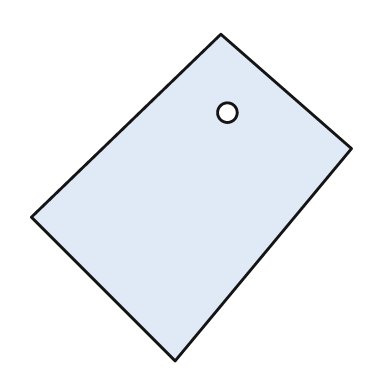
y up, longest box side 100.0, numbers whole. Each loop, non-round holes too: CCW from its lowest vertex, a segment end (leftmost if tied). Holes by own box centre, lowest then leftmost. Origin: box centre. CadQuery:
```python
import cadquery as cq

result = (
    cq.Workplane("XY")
    .moveTo(-5.0, -50.0)
    .lineTo(49.0, 15.0)
    .lineTo(9.0, 50.0)
    .lineTo(-49.0, -6.0)
    .close()
    .moveTo(11.0, 26.0)
    .circle(3.0)
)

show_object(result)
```